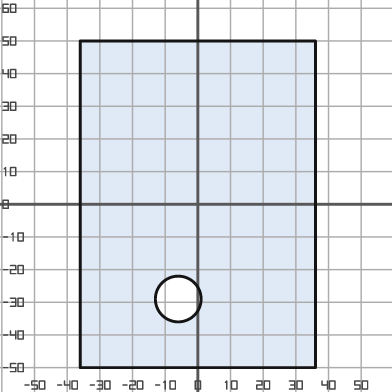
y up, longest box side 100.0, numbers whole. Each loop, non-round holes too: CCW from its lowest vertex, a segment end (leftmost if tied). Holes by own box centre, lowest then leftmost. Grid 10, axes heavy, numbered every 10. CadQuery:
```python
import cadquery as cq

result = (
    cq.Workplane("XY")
    .moveTo(-36.0, -50.0)
    .lineTo(36.0, -50.0)
    .lineTo(36.0, 50.0)
    .lineTo(-36.0, 50.0)
    .close()
    .moveTo(-6.0, -29.0)
    .circle(7.0)
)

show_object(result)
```